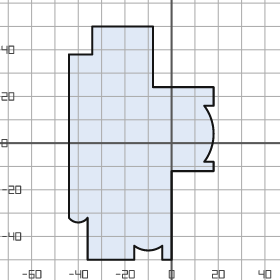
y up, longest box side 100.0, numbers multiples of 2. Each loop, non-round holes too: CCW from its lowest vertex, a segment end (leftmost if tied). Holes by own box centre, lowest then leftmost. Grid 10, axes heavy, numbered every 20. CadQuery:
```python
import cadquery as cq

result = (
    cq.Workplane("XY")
    .moveTo(-36.0, -50.0)
    .lineTo(-16.0, -50.0)
    .lineTo(-16.0, -44.0)
    .threePointArc((-10.0, -46.0), (-4.0, -44.0))
    .lineTo(-4.0, -50.0)
    .lineTo(0.0, -50.0)
    .lineTo(0.0, -12.0)
    .lineTo(18.0, -12.0)
    .lineTo(18.0, -8.0)
    .lineTo(14.0, -8.0)
    .threePointArc((18.0, 4.0), (14.0, 16.0))
    .lineTo(18.0, 16.0)
    .lineTo(18.0, 24.0)
    .lineTo(-8.0, 24.0)
    .lineTo(-8.0, 50.0)
    .lineTo(-34.0, 50.0)
    .lineTo(-34.0, 38.0)
    .lineTo(-44.0, 38.0)
    .lineTo(-44.0, -32.0)
    .threePointArc((-40.0, -34.0), (-36.0, -32.0))
    .close()
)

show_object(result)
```